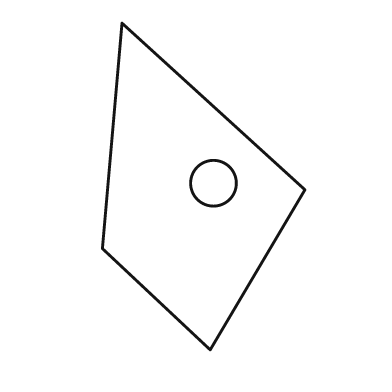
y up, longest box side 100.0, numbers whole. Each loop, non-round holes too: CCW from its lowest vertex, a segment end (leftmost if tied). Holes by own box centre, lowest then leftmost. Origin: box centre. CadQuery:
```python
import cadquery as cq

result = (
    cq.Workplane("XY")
    .moveTo(2.0, -50.0)
    .lineTo(31.0, -1.0)
    .lineTo(-25.0, 50.0)
    .lineTo(-31.0, -19.0)
    .close()
    .moveTo(3.0, 1.0)
    .circle(7.0)
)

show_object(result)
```